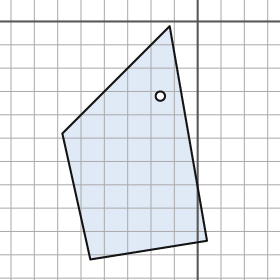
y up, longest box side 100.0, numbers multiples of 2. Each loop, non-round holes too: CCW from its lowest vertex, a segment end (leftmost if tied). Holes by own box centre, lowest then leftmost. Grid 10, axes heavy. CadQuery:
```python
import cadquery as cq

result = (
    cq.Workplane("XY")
    .moveTo(-46.0, -102.0)
    .lineTo(4.0, -94.0)
    .lineTo(-12.0, -2.0)
    .lineTo(-58.0, -48.0)
    .close()
    .moveTo(-16.0, -32.0)
    .circle(2.0)
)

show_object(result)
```